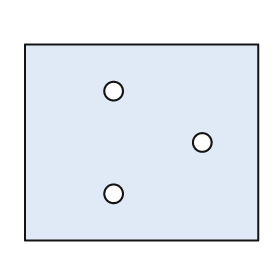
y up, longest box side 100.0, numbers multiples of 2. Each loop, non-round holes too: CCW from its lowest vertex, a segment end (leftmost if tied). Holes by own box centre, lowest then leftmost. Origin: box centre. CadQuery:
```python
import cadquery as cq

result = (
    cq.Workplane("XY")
    .moveTo(-50.0, -42.0)
    .lineTo(50.0, -42.0)
    .lineTo(50.0, 42.0)
    .lineTo(-50.0, 42.0)
    .close()
    .moveTo(-12.0, -22.0)
    .circle(4.0)
    .moveTo(26.0, 0.0)
    .circle(4.0)
    .moveTo(-12.0, 22.0)
    .circle(4.0)
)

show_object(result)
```